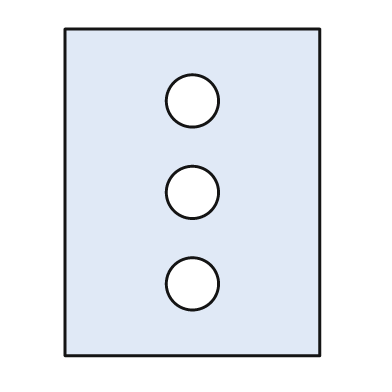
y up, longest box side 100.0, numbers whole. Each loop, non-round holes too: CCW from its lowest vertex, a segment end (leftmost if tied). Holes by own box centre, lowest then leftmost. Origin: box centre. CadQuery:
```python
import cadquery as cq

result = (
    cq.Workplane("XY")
    .moveTo(-39.0, -50.0)
    .lineTo(39.0, -50.0)
    .lineTo(39.0, 50.0)
    .lineTo(-39.0, 50.0)
    .close()
    .moveTo(0.0, -28.0)
    .circle(8.0)
    .moveTo(0.0, 0.0)
    .circle(8.0)
    .moveTo(0.0, 28.0)
    .circle(8.0)
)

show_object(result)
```